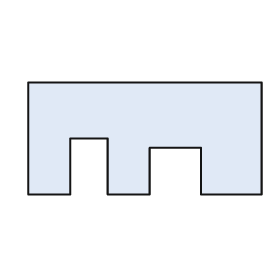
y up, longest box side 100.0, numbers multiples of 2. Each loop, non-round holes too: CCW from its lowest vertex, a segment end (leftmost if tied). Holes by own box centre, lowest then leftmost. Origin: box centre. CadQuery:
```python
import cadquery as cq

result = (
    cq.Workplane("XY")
    .moveTo(-50.0, -24.0)
    .lineTo(-32.0, -24.0)
    .lineTo(-32.0, 0.0)
    .lineTo(-16.0, 0.0)
    .lineTo(-16.0, -24.0)
    .lineTo(2.0, -24.0)
    .lineTo(2.0, -4.0)
    .lineTo(24.0, -4.0)
    .lineTo(24.0, -24.0)
    .lineTo(50.0, -24.0)
    .lineTo(50.0, 24.0)
    .lineTo(-50.0, 24.0)
    .close()
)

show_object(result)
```